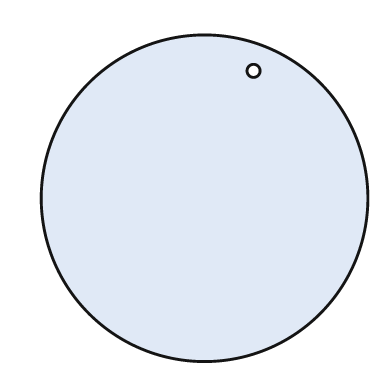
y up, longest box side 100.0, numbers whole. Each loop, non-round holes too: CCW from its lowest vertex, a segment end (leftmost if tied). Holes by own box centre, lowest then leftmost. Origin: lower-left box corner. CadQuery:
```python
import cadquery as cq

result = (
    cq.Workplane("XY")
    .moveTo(50.0, 50.0)
    .circle(50.0)
    .moveTo(65.0, 89.0)
    .circle(2.0)
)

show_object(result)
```